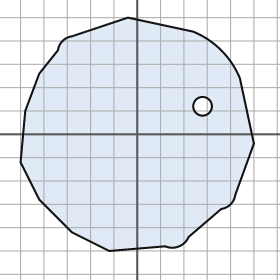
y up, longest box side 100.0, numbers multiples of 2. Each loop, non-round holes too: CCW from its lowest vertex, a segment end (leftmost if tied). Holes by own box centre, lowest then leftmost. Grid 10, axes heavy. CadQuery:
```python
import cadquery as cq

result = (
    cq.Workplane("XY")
    .moveTo(-12.0, -50.0)
    .lineTo(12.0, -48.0)
    .threePointArc((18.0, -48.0), (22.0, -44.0))
    .lineTo(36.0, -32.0)
    .threePointArc((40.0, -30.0), (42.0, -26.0))
    .lineTo(50.0, -4.0)
    .lineTo(44.0, 24.0)
    .threePointArc((36.0, 36.0), (24.0, 44.0))
    .lineTo(-4.0, 50.0)
    .lineTo(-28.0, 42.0)
    .threePointArc((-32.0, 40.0), (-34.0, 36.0))
    .lineTo(-42.0, 26.0)
    .lineTo(-48.0, 10.0)
    .lineTo(-50.0, -12.0)
    .lineTo(-42.0, -28.0)
    .lineTo(-28.0, -42.0)
    .close()
    .moveTo(28.0, 12.0)
    .circle(4.0)
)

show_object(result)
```